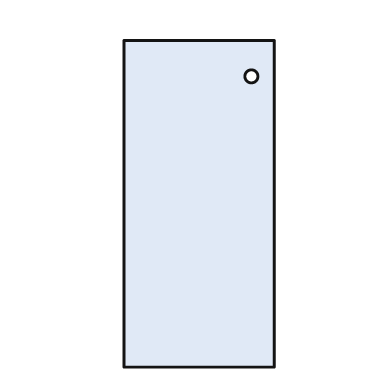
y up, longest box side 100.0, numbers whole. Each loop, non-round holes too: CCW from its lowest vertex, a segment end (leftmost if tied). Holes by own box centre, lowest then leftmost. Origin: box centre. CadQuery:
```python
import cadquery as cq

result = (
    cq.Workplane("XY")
    .moveTo(-23.0, -50.0)
    .lineTo(23.0, -50.0)
    .lineTo(23.0, 50.0)
    .lineTo(-23.0, 50.0)
    .close()
    .moveTo(16.0, 39.0)
    .circle(2.0)
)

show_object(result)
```